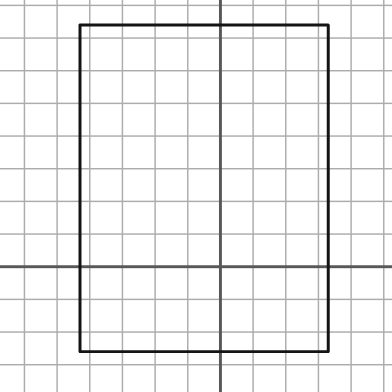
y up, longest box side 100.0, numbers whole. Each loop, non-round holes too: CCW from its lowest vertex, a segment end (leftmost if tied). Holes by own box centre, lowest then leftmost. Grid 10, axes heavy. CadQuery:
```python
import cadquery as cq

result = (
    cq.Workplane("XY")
    .moveTo(-43.0, -26.0)
    .lineTo(33.0, -26.0)
    .lineTo(33.0, 74.0)
    .lineTo(-43.0, 74.0)
    .close()
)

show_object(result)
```